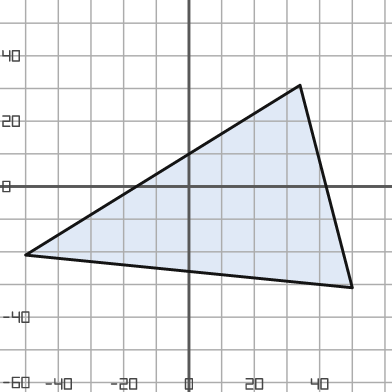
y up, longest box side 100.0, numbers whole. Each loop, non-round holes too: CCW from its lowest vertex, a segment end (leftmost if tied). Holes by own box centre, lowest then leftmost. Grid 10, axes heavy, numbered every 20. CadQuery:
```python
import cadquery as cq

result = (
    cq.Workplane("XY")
    .moveTo(50.0, -31.0)
    .lineTo(34.0, 31.0)
    .lineTo(-50.0, -21.0)
    .close()
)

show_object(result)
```